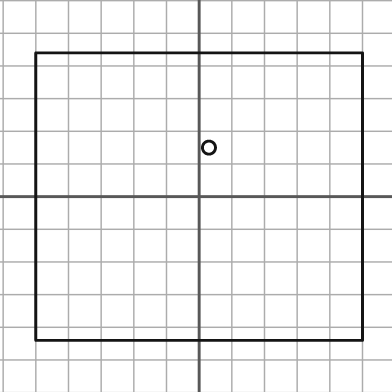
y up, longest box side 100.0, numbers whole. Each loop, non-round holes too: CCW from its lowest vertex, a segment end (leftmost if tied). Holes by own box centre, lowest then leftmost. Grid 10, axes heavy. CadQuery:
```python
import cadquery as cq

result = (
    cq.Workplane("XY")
    .moveTo(-50.0, -44.0)
    .lineTo(50.0, -44.0)
    .lineTo(50.0, 44.0)
    .lineTo(-50.0, 44.0)
    .close()
    .moveTo(3.0, 15.0)
    .circle(2.0)
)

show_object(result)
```